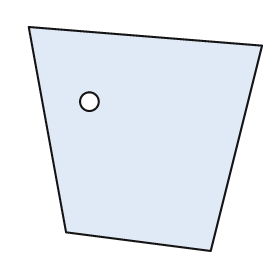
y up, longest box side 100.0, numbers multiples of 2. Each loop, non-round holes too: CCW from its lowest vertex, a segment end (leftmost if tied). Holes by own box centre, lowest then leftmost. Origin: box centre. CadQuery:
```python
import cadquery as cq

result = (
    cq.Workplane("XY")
    .moveTo(28.0, -48.0)
    .lineTo(50.0, 40.0)
    .lineTo(-50.0, 48.0)
    .lineTo(-34.0, -40.0)
    .close()
    .moveTo(-24.0, 16.0)
    .circle(4.0)
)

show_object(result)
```